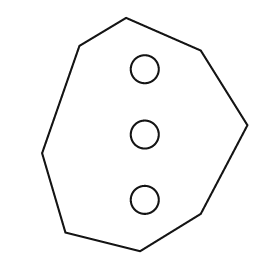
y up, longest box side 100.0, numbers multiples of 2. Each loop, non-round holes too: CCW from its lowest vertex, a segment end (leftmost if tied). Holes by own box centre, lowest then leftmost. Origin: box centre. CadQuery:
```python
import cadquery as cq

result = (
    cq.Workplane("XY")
    .moveTo(-2.0, -50.0)
    .lineTo(24.0, -34.0)
    .lineTo(44.0, 4.0)
    .lineTo(24.0, 36.0)
    .lineTo(-8.0, 50.0)
    .lineTo(-28.0, 38.0)
    .lineTo(-44.0, -8.0)
    .lineTo(-34.0, -42.0)
    .close()
    .moveTo(0.0, -28.0)
    .circle(6.0)
    .moveTo(0.0, 0.0)
    .circle(6.0)
    .moveTo(0.0, 28.0)
    .circle(6.0)
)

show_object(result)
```